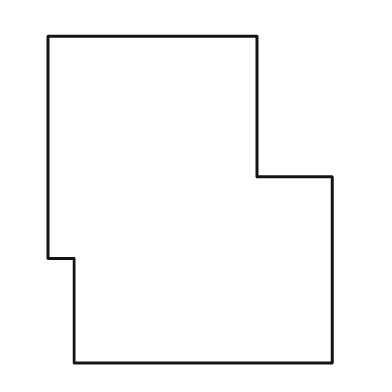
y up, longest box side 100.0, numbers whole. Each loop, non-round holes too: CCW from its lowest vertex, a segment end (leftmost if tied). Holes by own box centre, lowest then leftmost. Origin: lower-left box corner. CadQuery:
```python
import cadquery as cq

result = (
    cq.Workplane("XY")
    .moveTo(8.0, 0.0)
    .lineTo(87.0, 0.0)
    .lineTo(87.0, 57.0)
    .lineTo(64.0, 57.0)
    .lineTo(64.0, 100.0)
    .lineTo(0.0, 100.0)
    .lineTo(0.0, 32.0)
    .lineTo(8.0, 32.0)
    .close()
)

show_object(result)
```